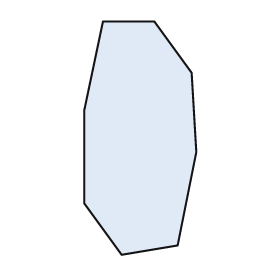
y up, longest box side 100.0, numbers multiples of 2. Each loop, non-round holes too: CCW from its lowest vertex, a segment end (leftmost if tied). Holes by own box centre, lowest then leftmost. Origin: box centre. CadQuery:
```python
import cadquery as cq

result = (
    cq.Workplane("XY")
    .moveTo(-8.0, -50.0)
    .lineTo(16.0, -46.0)
    .lineTo(24.0, -6.0)
    .lineTo(22.0, 28.0)
    .lineTo(6.0, 50.0)
    .lineTo(-16.0, 50.0)
    .lineTo(-24.0, 12.0)
    .lineTo(-24.0, -28.0)
    .close()
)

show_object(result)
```